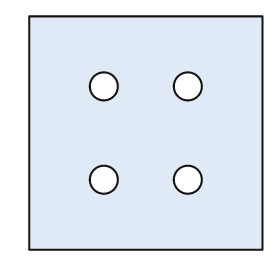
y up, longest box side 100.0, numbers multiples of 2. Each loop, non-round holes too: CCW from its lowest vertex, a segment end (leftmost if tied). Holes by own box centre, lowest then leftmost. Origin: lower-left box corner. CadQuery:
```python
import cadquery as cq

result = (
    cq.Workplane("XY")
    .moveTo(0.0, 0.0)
    .lineTo(100.0, 0.0)
    .lineTo(100.0, 100.0)
    .lineTo(0.0, 100.0)
    .close()
    .moveTo(32.0, 30.0)
    .circle(6.0)
    .moveTo(68.0, 30.0)
    .circle(6.0)
    .moveTo(32.0, 70.0)
    .circle(6.0)
    .moveTo(68.0, 70.0)
    .circle(6.0)
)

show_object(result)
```